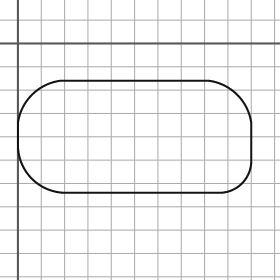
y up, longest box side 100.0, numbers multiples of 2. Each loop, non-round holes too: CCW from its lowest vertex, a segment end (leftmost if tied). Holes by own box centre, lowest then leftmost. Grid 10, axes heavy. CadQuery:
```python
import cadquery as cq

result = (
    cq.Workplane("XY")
    .moveTo(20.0, -64.0)
    .lineTo(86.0, -64.0)
    .threePointArc((96.0, -60.0), (100.0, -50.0))
    .lineTo(100.0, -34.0)
    .threePointArc((94.0, -22.0), (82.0, -16.0))
    .lineTo(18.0, -16.0)
    .threePointArc((6.0, -22.0), (0.0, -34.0))
    .lineTo(0.0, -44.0)
    .threePointArc((6.0, -58.0), (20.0, -64.0))
    .close()
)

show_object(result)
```